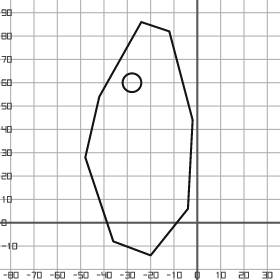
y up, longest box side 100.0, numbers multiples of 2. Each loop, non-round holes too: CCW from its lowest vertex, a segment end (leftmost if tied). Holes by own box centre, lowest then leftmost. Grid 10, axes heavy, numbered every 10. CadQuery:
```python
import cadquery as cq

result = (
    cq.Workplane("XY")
    .moveTo(-20.0, -14.0)
    .lineTo(-4.0, 6.0)
    .lineTo(-2.0, 44.0)
    .lineTo(-12.0, 82.0)
    .lineTo(-24.0, 86.0)
    .lineTo(-42.0, 54.0)
    .lineTo(-48.0, 28.0)
    .lineTo(-36.0, -8.0)
    .close()
    .moveTo(-28.0, 60.0)
    .circle(4.0)
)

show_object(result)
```